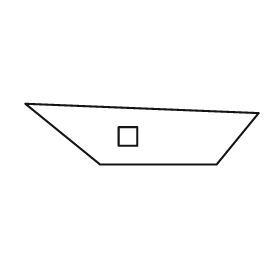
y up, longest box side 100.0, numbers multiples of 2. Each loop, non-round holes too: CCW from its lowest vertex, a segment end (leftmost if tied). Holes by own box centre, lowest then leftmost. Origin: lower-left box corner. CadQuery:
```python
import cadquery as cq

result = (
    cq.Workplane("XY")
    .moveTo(32.0, 0.0)
    .lineTo(82.0, 0.0)
    .lineTo(100.0, 22.0)
    .lineTo(0.0, 26.0)
    .close()
    .moveTo(40.0, 8.0)
    .lineTo(48.0, 8.0)
    .lineTo(48.0, 16.0)
    .lineTo(40.0, 16.0)
    .close()
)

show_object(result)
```